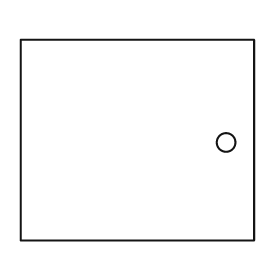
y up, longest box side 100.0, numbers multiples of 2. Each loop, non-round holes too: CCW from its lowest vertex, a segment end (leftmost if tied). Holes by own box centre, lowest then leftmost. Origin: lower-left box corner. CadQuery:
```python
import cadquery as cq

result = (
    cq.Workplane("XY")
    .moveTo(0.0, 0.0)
    .lineTo(100.0, 0.0)
    .lineTo(100.0, 86.0)
    .lineTo(0.0, 86.0)
    .close()
    .moveTo(88.0, 42.0)
    .circle(4.0)
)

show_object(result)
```